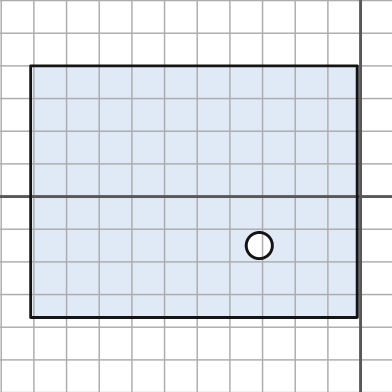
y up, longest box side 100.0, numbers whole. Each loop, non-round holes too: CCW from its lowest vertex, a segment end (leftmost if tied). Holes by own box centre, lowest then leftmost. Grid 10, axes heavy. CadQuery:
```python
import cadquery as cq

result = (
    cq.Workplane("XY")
    .moveTo(-101.0, -37.0)
    .lineTo(-1.0, -37.0)
    .lineTo(-1.0, 40.0)
    .lineTo(-101.0, 40.0)
    .close()
    .moveTo(-31.0, -15.0)
    .circle(4.0)
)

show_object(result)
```